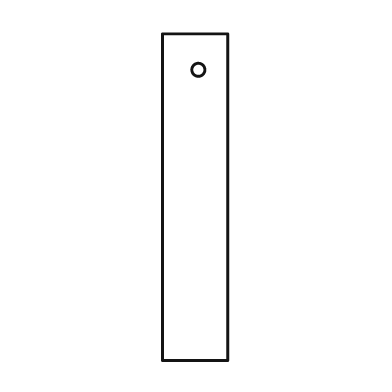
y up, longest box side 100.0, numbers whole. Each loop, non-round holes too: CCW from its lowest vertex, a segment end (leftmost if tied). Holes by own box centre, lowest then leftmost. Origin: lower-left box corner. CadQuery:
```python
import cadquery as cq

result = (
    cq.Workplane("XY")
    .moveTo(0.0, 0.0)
    .lineTo(20.0, 0.0)
    .lineTo(20.0, 100.0)
    .lineTo(0.0, 100.0)
    .close()
    .moveTo(11.0, 89.0)
    .circle(2.0)
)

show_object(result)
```